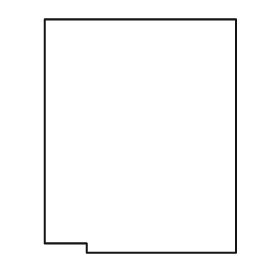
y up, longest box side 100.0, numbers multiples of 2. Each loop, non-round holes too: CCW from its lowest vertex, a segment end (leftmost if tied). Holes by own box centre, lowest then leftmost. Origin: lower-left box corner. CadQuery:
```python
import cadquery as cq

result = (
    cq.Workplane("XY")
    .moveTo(18.0, 0.0)
    .lineTo(82.0, 0.0)
    .lineTo(82.0, 100.0)
    .lineTo(0.0, 100.0)
    .lineTo(0.0, 4.0)
    .lineTo(18.0, 4.0)
    .close()
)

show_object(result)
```